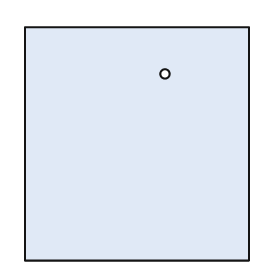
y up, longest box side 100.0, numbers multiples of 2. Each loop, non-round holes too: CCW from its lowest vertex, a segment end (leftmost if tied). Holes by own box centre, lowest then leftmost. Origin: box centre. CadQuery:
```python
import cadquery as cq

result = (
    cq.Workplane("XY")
    .moveTo(-48.0, -50.0)
    .lineTo(48.0, -50.0)
    .lineTo(48.0, 50.0)
    .lineTo(-48.0, 50.0)
    .close()
    .moveTo(12.0, 30.0)
    .circle(2.0)
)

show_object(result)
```